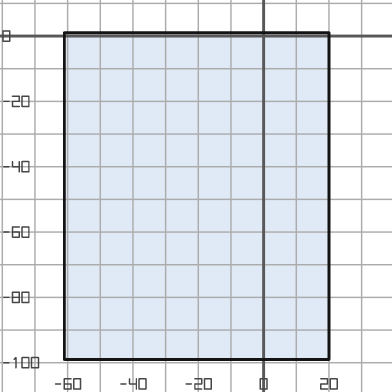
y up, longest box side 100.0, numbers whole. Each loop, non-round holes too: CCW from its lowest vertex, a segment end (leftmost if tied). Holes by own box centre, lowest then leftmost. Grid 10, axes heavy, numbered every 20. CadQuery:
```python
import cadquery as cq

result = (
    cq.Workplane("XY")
    .moveTo(-61.0, -99.0)
    .lineTo(20.0, -99.0)
    .lineTo(20.0, 1.0)
    .lineTo(-61.0, 1.0)
    .close()
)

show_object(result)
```